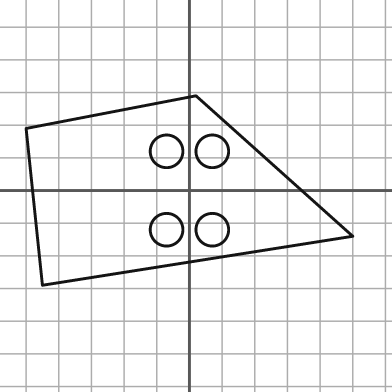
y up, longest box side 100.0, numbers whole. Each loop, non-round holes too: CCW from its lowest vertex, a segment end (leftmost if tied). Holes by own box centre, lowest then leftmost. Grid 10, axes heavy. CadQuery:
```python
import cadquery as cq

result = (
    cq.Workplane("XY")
    .moveTo(-45.0, -29.0)
    .lineTo(50.0, -14.0)
    .lineTo(2.0, 29.0)
    .lineTo(-50.0, 19.0)
    .close()
    .moveTo(-7.0, -12.0)
    .circle(5.0)
    .moveTo(7.0, -12.0)
    .circle(5.0)
    .moveTo(-7.0, 12.0)
    .circle(5.0)
    .moveTo(7.0, 12.0)
    .circle(5.0)
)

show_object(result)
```